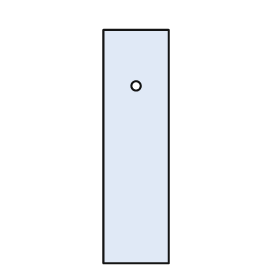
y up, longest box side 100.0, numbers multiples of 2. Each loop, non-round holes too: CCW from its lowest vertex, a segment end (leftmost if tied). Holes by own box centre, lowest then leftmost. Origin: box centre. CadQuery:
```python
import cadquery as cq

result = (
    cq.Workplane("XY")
    .moveTo(-14.0, -50.0)
    .lineTo(14.0, -50.0)
    .lineTo(14.0, 50.0)
    .lineTo(-14.0, 50.0)
    .close()
    .moveTo(0.0, 26.0)
    .circle(2.0)
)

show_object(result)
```